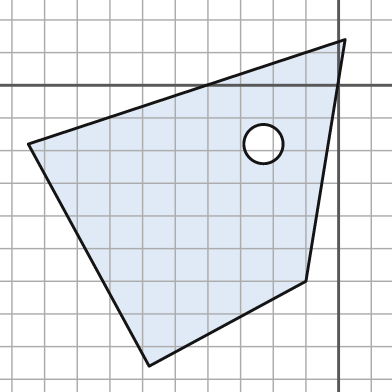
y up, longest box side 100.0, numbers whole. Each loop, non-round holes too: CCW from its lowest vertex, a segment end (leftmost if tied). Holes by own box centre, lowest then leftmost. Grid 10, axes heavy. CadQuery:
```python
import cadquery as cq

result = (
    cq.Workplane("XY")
    .moveTo(-58.0, -86.0)
    .lineTo(-10.0, -60.0)
    .lineTo(2.0, 14.0)
    .lineTo(-95.0, -18.0)
    .close()
    .moveTo(-23.0, -18.0)
    .circle(6.0)
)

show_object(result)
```